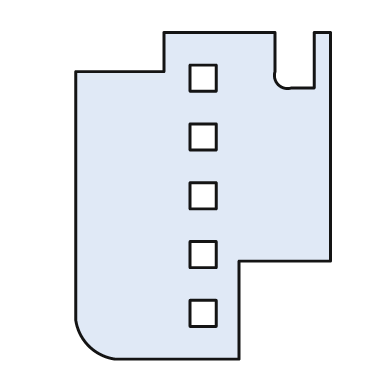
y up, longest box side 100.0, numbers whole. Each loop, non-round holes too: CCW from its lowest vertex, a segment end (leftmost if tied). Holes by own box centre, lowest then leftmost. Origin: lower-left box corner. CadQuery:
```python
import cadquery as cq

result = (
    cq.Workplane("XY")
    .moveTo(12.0, 0.0)
    .lineTo(50.0, 0.0)
    .lineTo(50.0, 30.0)
    .lineTo(78.0, 30.0)
    .lineTo(78.0, 100.0)
    .lineTo(73.0, 100.0)
    .lineTo(73.0, 83.0)
    .lineTo(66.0, 83.0)
    .threePointArc((62.0, 84.0), (61.0, 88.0))
    .lineTo(61.0, 100.0)
    .lineTo(27.0, 100.0)
    .lineTo(27.0, 88.0)
    .lineTo(0.0, 88.0)
    .lineTo(0.0, 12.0)
    .threePointArc((4.0, 4.0), (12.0, 0.0))
    .close()
    .moveTo(35.0, 10.0)
    .lineTo(43.0, 10.0)
    .lineTo(43.0, 18.0)
    .lineTo(35.0, 18.0)
    .close()
    .moveTo(35.0, 28.0)
    .lineTo(43.0, 28.0)
    .lineTo(43.0, 36.0)
    .lineTo(35.0, 36.0)
    .close()
    .moveTo(35.0, 46.0)
    .lineTo(43.0, 46.0)
    .lineTo(43.0, 54.0)
    .lineTo(35.0, 54.0)
    .close()
    .moveTo(35.0, 64.0)
    .lineTo(43.0, 64.0)
    .lineTo(43.0, 72.0)
    .lineTo(35.0, 72.0)
    .close()
    .moveTo(35.0, 82.0)
    .lineTo(43.0, 82.0)
    .lineTo(43.0, 90.0)
    .lineTo(35.0, 90.0)
    .close()
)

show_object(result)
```